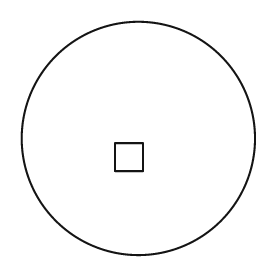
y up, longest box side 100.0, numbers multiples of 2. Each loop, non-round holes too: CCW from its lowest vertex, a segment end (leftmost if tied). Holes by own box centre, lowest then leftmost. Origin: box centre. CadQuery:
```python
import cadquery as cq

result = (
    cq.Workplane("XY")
    .moveTo(0.0, 0.0)
    .circle(50.0)
    .moveTo(-10.0, -14.0)
    .lineTo(2.0, -14.0)
    .lineTo(2.0, -2.0)
    .lineTo(-10.0, -2.0)
    .close()
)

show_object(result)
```